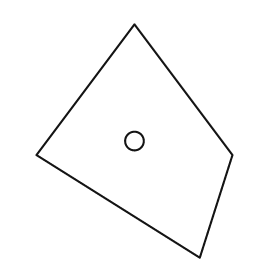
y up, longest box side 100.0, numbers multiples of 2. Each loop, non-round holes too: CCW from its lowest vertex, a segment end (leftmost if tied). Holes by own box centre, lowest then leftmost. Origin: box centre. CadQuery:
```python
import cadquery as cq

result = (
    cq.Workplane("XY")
    .moveTo(28.0, -50.0)
    .lineTo(42.0, -6.0)
    .lineTo(0.0, 50.0)
    .lineTo(-42.0, -6.0)
    .close()
    .moveTo(0.0, 0.0)
    .circle(4.0)
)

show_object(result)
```